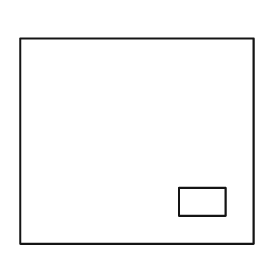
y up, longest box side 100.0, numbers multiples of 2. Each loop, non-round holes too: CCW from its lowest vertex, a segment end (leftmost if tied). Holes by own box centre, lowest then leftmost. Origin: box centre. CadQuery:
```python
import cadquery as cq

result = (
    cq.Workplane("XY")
    .moveTo(-50.0, -44.0)
    .lineTo(50.0, -44.0)
    .lineTo(50.0, 44.0)
    .lineTo(-50.0, 44.0)
    .close()
    .moveTo(18.0, -32.0)
    .lineTo(38.0, -32.0)
    .lineTo(38.0, -20.0)
    .lineTo(18.0, -20.0)
    .close()
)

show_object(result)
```